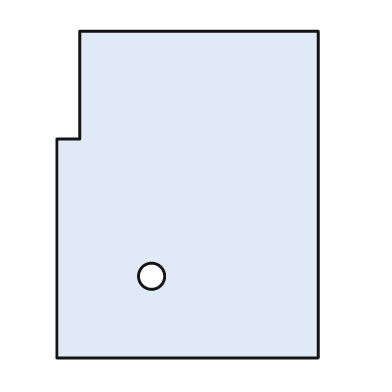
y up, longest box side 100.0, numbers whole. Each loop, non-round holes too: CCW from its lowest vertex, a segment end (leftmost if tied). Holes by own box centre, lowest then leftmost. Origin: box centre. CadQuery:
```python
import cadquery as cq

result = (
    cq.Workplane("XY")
    .moveTo(-40.0, -50.0)
    .lineTo(40.0, -50.0)
    .lineTo(40.0, 50.0)
    .lineTo(-33.0, 50.0)
    .lineTo(-33.0, 17.0)
    .lineTo(-40.0, 17.0)
    .close()
    .moveTo(-11.0, -25.0)
    .circle(4.0)
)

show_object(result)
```